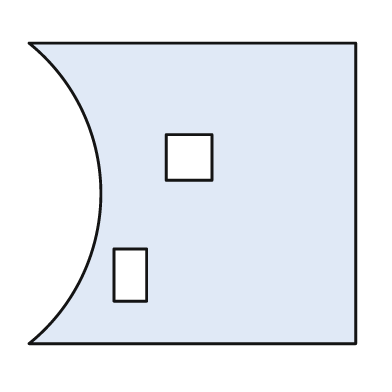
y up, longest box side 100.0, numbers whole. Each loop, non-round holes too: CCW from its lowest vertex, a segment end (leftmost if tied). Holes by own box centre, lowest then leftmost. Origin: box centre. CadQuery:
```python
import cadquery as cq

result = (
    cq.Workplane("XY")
    .moveTo(-50.0, -46.0)
    .lineTo(50.0, -46.0)
    .lineTo(50.0, 46.0)
    .lineTo(-50.0, 46.0)
    .threePointArc((-28.0, 0.0), (-50.0, -46.0))
    .close()
    .moveTo(-24.0, -33.0)
    .lineTo(-14.0, -33.0)
    .lineTo(-14.0, -17.0)
    .lineTo(-24.0, -17.0)
    .close()
    .moveTo(-8.0, 4.0)
    .lineTo(6.0, 4.0)
    .lineTo(6.0, 18.0)
    .lineTo(-8.0, 18.0)
    .close()
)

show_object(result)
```